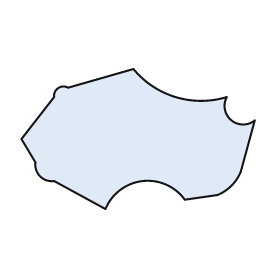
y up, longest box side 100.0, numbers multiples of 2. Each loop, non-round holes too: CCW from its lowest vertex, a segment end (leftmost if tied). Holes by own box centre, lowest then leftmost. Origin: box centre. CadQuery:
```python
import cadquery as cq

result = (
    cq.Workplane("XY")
    .moveTo(-14.0, -30.0)
    .threePointArc((2.0, -18.0), (20.0, -26.0))
    .lineTo(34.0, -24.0)
    .threePointArc((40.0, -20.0), (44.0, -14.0))
    .lineTo(50.0, 8.0)
    .threePointArc((40.0, 8.0), (38.0, 18.0))
    .threePointArc((16.0, 18.0), (-2.0, 30.0))
    .lineTo(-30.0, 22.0)
    .threePointArc((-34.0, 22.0), (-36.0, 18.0))
    .lineTo(-50.0, 0.0)
    .lineTo(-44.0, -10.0)
    .threePointArc((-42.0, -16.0), (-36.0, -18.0))
    .close()
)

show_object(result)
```